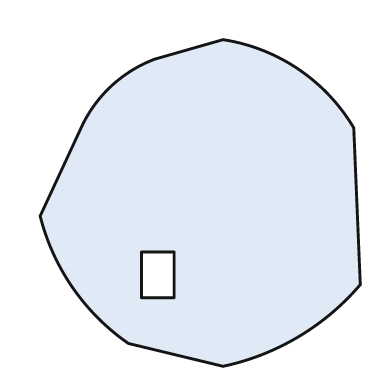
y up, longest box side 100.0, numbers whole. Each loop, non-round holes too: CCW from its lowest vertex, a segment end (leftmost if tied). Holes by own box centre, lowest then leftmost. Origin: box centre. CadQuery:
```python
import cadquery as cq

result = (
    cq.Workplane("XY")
    .moveTo(7.0, -50.0)
    .threePointArc((30.0, -41.0), (49.0, -25.0))
    .lineTo(47.0, 23.0)
    .threePointArc((30.0, 41.0), (7.0, 50.0))
    .lineTo(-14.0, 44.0)
    .threePointArc((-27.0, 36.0), (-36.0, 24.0))
    .lineTo(-49.0, -4.0)
    .threePointArc((-39.0, -26.0), (-22.0, -43.0))
    .close()
    .moveTo(-18.0, -29.0)
    .lineTo(-8.0, -29.0)
    .lineTo(-8.0, -15.0)
    .lineTo(-18.0, -15.0)
    .close()
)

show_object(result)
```